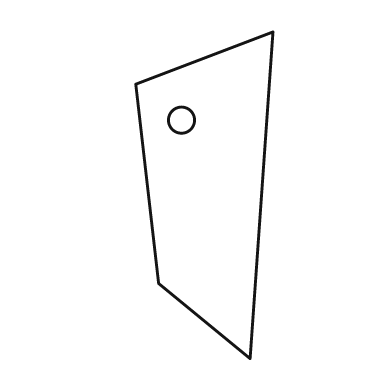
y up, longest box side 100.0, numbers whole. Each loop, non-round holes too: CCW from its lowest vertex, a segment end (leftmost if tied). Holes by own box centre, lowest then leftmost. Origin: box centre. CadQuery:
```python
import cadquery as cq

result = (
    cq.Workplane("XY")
    .moveTo(14.0, -50.0)
    .lineTo(21.0, 50.0)
    .lineTo(-21.0, 34.0)
    .lineTo(-14.0, -27.0)
    .close()
    .moveTo(-7.0, 23.0)
    .circle(4.0)
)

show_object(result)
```